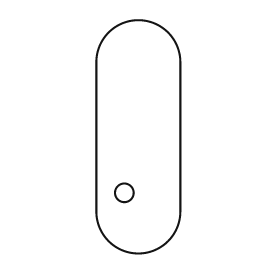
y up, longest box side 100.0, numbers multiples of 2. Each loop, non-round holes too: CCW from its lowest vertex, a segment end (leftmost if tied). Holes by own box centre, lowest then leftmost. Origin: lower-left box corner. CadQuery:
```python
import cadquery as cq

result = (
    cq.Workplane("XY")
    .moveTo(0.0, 18.0)
    .threePointArc((18.0, 0.0), (36.0, 18.0))
    .lineTo(36.0, 82.0)
    .threePointArc((18.0, 100.0), (0.0, 82.0))
    .close()
    .moveTo(12.0, 26.0)
    .circle(4.0)
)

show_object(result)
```